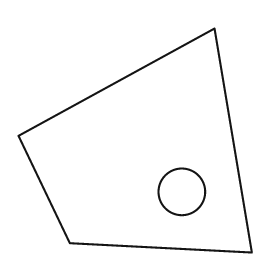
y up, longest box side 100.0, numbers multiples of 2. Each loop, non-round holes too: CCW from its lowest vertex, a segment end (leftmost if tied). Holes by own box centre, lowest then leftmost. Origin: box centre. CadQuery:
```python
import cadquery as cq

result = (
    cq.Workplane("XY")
    .moveTo(50.0, -48.0)
    .lineTo(34.0, 48.0)
    .lineTo(-50.0, 2.0)
    .lineTo(-28.0, -44.0)
    .close()
    .moveTo(20.0, -22.0)
    .circle(10.0)
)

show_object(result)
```